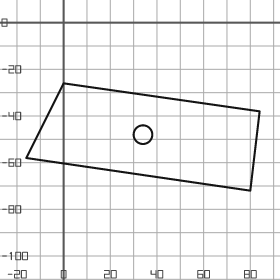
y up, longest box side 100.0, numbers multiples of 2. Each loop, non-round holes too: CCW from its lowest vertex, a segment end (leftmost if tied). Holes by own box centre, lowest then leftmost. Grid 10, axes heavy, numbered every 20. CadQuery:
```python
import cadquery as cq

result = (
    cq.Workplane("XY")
    .moveTo(80.0, -72.0)
    .lineTo(84.0, -38.0)
    .lineTo(0.0, -26.0)
    .lineTo(-16.0, -58.0)
    .close()
    .moveTo(34.0, -48.0)
    .circle(4.0)
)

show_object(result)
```